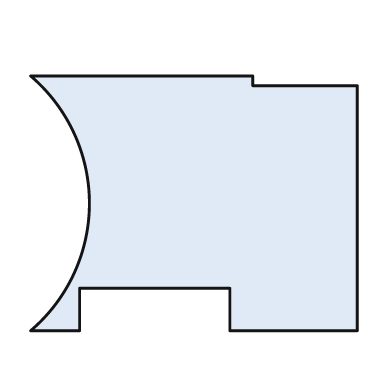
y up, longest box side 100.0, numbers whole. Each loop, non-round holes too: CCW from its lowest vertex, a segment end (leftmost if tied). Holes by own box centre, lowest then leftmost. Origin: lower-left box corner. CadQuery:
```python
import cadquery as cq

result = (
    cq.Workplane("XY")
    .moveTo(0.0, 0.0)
    .lineTo(15.0, 0.0)
    .lineTo(15.0, 13.0)
    .lineTo(61.0, 13.0)
    .lineTo(61.0, 0.0)
    .lineTo(100.0, 0.0)
    .lineTo(100.0, 75.0)
    .lineTo(68.0, 75.0)
    .lineTo(68.0, 78.0)
    .lineTo(0.0, 78.0)
    .threePointArc((18.0, 39.0), (0.0, 0.0))
    .close()
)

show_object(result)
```